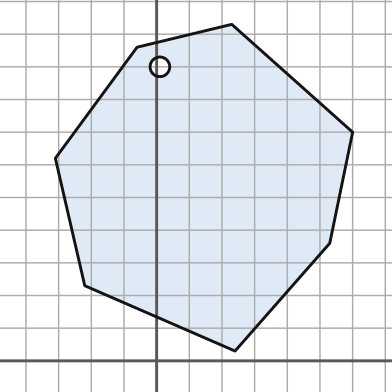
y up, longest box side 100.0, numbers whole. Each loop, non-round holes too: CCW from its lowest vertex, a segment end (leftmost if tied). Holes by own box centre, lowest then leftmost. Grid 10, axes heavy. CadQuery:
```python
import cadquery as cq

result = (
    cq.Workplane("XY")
    .moveTo(24.0, 3.0)
    .lineTo(53.0, 36.0)
    .lineTo(60.0, 70.0)
    .lineTo(23.0, 103.0)
    .lineTo(-6.0, 96.0)
    .lineTo(-31.0, 62.0)
    .lineTo(-22.0, 23.0)
    .close()
    .moveTo(1.0, 90.0)
    .circle(3.0)
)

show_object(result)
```